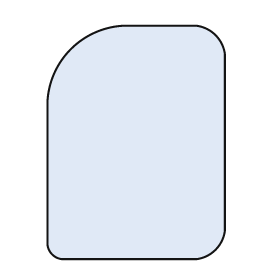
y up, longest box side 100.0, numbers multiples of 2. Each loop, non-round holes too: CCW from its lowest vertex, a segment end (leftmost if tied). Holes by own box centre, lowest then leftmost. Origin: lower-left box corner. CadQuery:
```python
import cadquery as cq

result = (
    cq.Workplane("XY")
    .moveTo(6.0, 0.0)
    .lineTo(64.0, 0.0)
    .threePointArc((72.0, 4.0), (76.0, 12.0))
    .lineTo(76.0, 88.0)
    .threePointArc((72.0, 96.0), (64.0, 100.0))
    .lineTo(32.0, 100.0)
    .threePointArc((10.0, 90.0), (0.0, 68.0))
    .lineTo(0.0, 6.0)
    .threePointArc((2.0, 2.0), (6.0, 0.0))
    .close()
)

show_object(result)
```